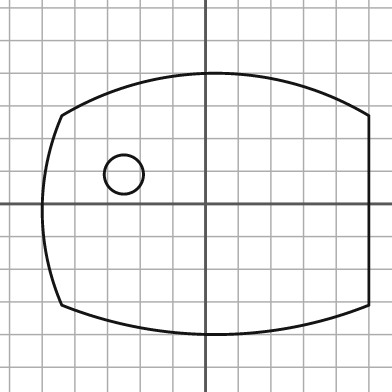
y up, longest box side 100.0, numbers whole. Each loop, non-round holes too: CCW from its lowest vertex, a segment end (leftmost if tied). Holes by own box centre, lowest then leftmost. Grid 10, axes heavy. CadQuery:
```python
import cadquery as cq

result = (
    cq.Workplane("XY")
    .moveTo(-44.0, -31.0)
    .threePointArc((3.0, -40.0), (50.0, -31.0))
    .lineTo(50.0, 27.0)
    .threePointArc((3.0, 40.0), (-44.0, 27.0))
    .threePointArc((-50.0, -2.0), (-44.0, -31.0))
    .close()
    .moveTo(-25.0, 9.0)
    .circle(6.0)
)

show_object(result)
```